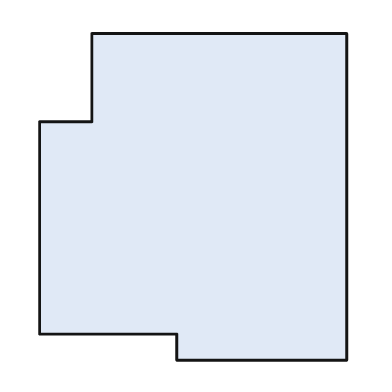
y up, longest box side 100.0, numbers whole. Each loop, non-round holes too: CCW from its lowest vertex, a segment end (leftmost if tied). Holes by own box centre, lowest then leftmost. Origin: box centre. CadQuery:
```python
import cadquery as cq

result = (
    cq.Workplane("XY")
    .moveTo(-5.0, -50.0)
    .lineTo(47.0, -50.0)
    .lineTo(47.0, 50.0)
    .lineTo(-31.0, 50.0)
    .lineTo(-31.0, 23.0)
    .lineTo(-47.0, 23.0)
    .lineTo(-47.0, -42.0)
    .lineTo(-5.0, -42.0)
    .close()
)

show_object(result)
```